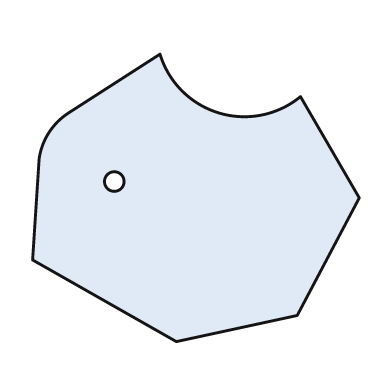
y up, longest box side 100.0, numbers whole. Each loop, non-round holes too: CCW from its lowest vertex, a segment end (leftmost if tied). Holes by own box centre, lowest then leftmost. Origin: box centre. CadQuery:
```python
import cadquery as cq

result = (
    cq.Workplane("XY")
    .moveTo(-6.0, -44.0)
    .lineTo(31.0, -36.0)
    .lineTo(50.0, 0.0)
    .lineTo(32.0, 31.0)
    .threePointArc((7.0, 26.0), (-11.0, 44.0))
    .lineTo(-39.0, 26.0)
    .threePointArc((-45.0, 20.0), (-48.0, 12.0))
    .lineTo(-50.0, -19.0)
    .close()
    .moveTo(-25.0, 5.0)
    .circle(3.0)
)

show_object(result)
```